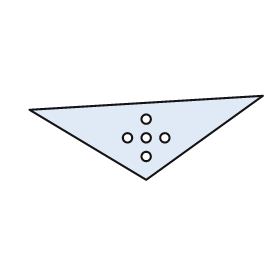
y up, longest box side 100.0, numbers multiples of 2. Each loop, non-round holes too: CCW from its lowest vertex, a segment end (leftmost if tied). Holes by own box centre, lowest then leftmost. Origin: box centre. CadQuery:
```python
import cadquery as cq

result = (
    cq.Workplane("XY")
    .moveTo(0.0, -18.0)
    .lineTo(50.0, 18.0)
    .lineTo(-50.0, 12.0)
    .close()
    .moveTo(0.0, -8.0)
    .circle(2.0)
    .moveTo(-8.0, 0.0)
    .circle(2.0)
    .moveTo(0.0, 0.0)
    .circle(2.0)
    .moveTo(8.0, 0.0)
    .circle(2.0)
    .moveTo(0.0, 8.0)
    .circle(2.0)
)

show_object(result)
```